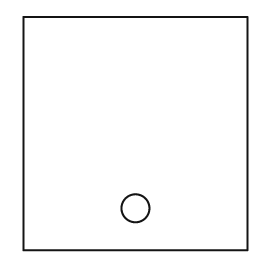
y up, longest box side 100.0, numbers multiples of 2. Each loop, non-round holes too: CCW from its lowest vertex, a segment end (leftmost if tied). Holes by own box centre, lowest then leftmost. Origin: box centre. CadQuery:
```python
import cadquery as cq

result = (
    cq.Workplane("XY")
    .moveTo(-48.0, -50.0)
    .lineTo(48.0, -50.0)
    .lineTo(48.0, 50.0)
    .lineTo(-48.0, 50.0)
    .close()
    .moveTo(0.0, -32.0)
    .circle(6.0)
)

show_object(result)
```